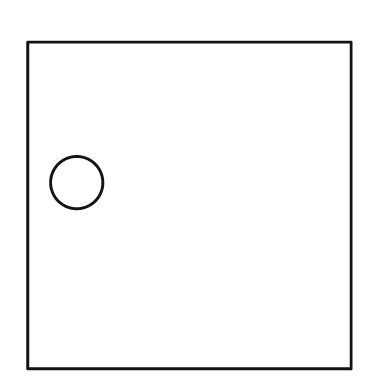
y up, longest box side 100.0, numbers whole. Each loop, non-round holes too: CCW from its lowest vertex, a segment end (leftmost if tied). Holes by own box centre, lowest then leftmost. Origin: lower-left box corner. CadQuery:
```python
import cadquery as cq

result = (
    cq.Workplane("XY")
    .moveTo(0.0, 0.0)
    .lineTo(99.0, 0.0)
    .lineTo(99.0, 100.0)
    .lineTo(0.0, 100.0)
    .close()
    .moveTo(15.0, 57.0)
    .circle(8.0)
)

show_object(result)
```